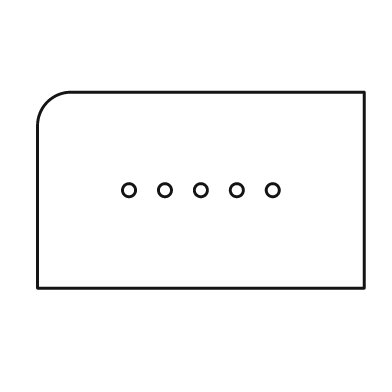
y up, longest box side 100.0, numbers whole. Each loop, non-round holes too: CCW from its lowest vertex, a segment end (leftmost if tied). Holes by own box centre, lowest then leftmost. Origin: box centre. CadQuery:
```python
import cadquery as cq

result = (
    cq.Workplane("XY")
    .moveTo(-50.0, -30.0)
    .lineTo(50.0, -30.0)
    .lineTo(50.0, 30.0)
    .lineTo(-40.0, 30.0)
    .threePointArc((-47.0, 27.0), (-50.0, 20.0))
    .close()
    .moveTo(-22.0, 0.0)
    .circle(2.0)
    .moveTo(-11.0, 0.0)
    .circle(2.0)
    .moveTo(0.0, 0.0)
    .circle(2.0)
    .moveTo(11.0, 0.0)
    .circle(2.0)
    .moveTo(22.0, 0.0)
    .circle(2.0)
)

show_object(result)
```